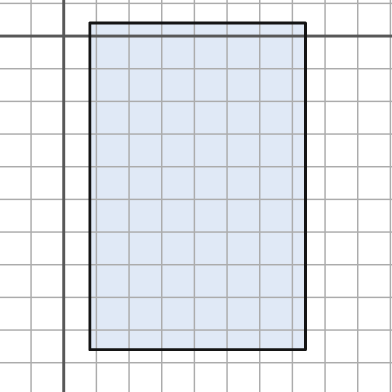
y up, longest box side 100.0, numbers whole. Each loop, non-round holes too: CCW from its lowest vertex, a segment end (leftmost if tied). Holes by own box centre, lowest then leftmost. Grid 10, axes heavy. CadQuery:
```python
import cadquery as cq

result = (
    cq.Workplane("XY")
    .moveTo(8.0, -96.0)
    .lineTo(74.0, -96.0)
    .lineTo(74.0, 4.0)
    .lineTo(8.0, 4.0)
    .close()
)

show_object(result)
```